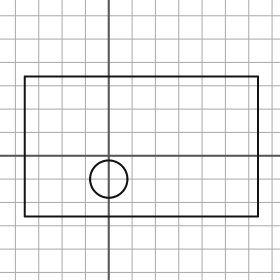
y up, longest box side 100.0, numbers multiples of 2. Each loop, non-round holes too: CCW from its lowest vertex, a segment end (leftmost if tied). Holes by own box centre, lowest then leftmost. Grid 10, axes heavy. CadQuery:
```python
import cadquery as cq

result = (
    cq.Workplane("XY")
    .moveTo(-36.0, -26.0)
    .lineTo(64.0, -26.0)
    .lineTo(64.0, 34.0)
    .lineTo(-36.0, 34.0)
    .close()
    .moveTo(0.0, -10.0)
    .circle(8.0)
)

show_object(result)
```